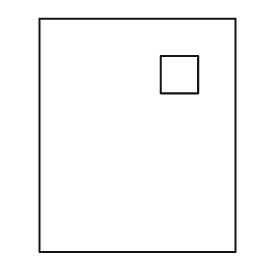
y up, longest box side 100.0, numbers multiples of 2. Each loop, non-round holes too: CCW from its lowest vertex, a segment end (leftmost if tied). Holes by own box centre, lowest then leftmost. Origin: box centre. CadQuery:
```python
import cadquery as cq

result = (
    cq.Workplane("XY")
    .moveTo(-42.0, -50.0)
    .lineTo(42.0, -50.0)
    .lineTo(42.0, 50.0)
    .lineTo(-42.0, 50.0)
    .close()
    .moveTo(10.0, 18.0)
    .lineTo(26.0, 18.0)
    .lineTo(26.0, 34.0)
    .lineTo(10.0, 34.0)
    .close()
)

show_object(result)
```